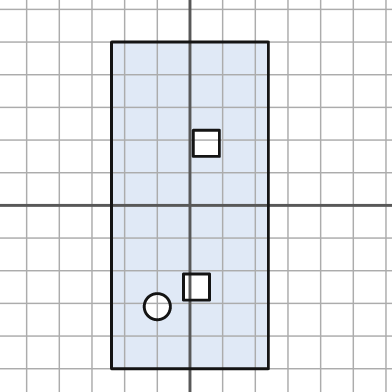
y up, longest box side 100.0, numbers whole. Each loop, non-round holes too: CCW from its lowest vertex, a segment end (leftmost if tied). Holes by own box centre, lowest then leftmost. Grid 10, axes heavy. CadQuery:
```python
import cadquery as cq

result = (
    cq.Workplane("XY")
    .moveTo(-24.0, -50.0)
    .lineTo(24.0, -50.0)
    .lineTo(24.0, 50.0)
    .lineTo(-24.0, 50.0)
    .close()
    .moveTo(-10.0, -31.0)
    .circle(4.0)
    .moveTo(-2.0, -29.0)
    .lineTo(6.0, -29.0)
    .lineTo(6.0, -21.0)
    .lineTo(-2.0, -21.0)
    .close()
    .moveTo(1.0, 15.0)
    .lineTo(9.0, 15.0)
    .lineTo(9.0, 23.0)
    .lineTo(1.0, 23.0)
    .close()
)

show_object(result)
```